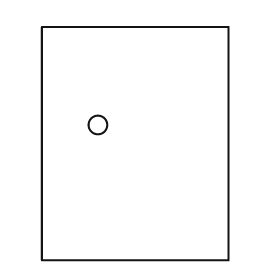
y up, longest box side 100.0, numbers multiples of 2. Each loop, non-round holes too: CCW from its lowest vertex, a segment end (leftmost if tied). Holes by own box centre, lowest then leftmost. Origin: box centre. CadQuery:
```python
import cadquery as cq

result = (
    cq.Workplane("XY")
    .moveTo(-40.0, -50.0)
    .lineTo(40.0, -50.0)
    .lineTo(40.0, 50.0)
    .lineTo(-40.0, 50.0)
    .close()
    .moveTo(-16.0, 8.0)
    .circle(4.0)
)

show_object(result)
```